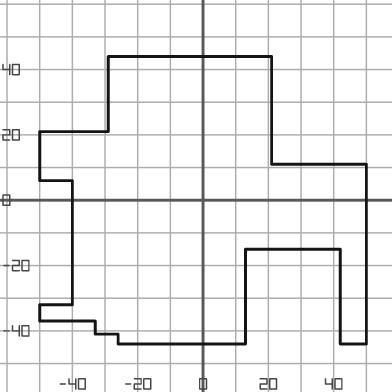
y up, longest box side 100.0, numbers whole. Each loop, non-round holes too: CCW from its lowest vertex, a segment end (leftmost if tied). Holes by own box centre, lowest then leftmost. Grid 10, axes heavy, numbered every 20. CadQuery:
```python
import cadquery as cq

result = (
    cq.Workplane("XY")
    .moveTo(-26.0, -44.0)
    .lineTo(13.0, -44.0)
    .lineTo(13.0, -15.0)
    .lineTo(42.0, -15.0)
    .lineTo(42.0, -44.0)
    .lineTo(50.0, -44.0)
    .lineTo(50.0, 11.0)
    .lineTo(21.0, 11.0)
    .lineTo(21.0, 44.0)
    .lineTo(-29.0, 44.0)
    .lineTo(-29.0, 21.0)
    .lineTo(-50.0, 21.0)
    .lineTo(-50.0, 6.0)
    .lineTo(-40.0, 6.0)
    .lineTo(-40.0, -32.0)
    .lineTo(-50.0, -32.0)
    .lineTo(-50.0, -37.0)
    .lineTo(-33.0, -37.0)
    .lineTo(-33.0, -41.0)
    .lineTo(-26.0, -41.0)
    .close()
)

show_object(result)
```